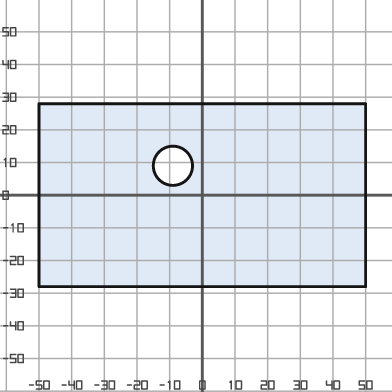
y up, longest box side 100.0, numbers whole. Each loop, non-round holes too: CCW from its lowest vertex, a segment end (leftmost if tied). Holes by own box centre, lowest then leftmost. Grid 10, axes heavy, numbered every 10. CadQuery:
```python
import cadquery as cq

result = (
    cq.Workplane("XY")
    .moveTo(-50.0, -28.0)
    .lineTo(50.0, -28.0)
    .lineTo(50.0, 28.0)
    .lineTo(-50.0, 28.0)
    .close()
    .moveTo(-9.0, 9.0)
    .circle(6.0)
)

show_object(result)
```